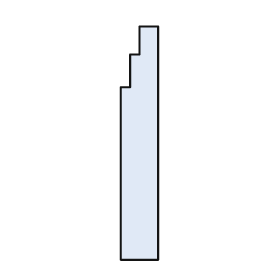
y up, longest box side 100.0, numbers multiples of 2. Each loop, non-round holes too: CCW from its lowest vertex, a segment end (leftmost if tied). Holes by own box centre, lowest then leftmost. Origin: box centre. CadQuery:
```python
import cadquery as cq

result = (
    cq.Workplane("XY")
    .moveTo(-8.0, -50.0)
    .lineTo(8.0, -50.0)
    .lineTo(8.0, 50.0)
    .lineTo(0.0, 50.0)
    .lineTo(0.0, 38.0)
    .lineTo(-4.0, 38.0)
    .lineTo(-4.0, 24.0)
    .lineTo(-8.0, 24.0)
    .close()
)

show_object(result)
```